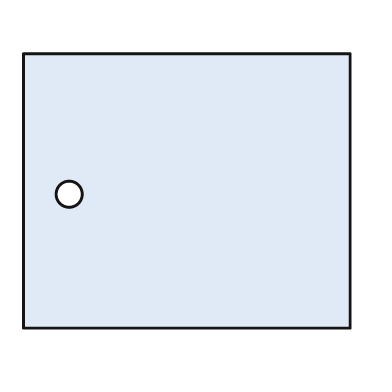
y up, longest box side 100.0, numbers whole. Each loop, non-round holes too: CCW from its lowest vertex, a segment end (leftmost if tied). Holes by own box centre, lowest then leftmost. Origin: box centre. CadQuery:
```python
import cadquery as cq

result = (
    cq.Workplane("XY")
    .moveTo(-50.0, -42.0)
    .lineTo(50.0, -42.0)
    .lineTo(50.0, 42.0)
    .lineTo(-50.0, 42.0)
    .close()
    .moveTo(-36.0, -1.0)
    .circle(4.0)
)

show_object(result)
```